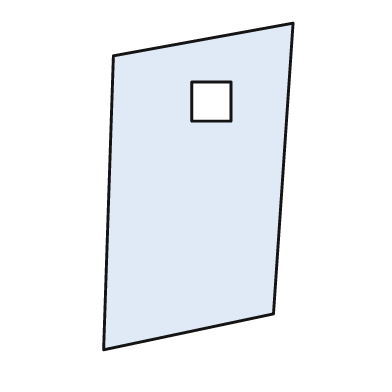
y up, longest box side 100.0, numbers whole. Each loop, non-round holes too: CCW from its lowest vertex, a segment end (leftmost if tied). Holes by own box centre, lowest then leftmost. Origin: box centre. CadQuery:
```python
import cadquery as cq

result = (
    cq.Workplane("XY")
    .moveTo(-29.0, -50.0)
    .lineTo(23.0, -39.0)
    .lineTo(29.0, 50.0)
    .lineTo(-26.0, 40.0)
    .close()
    .moveTo(-2.0, 20.0)
    .lineTo(10.0, 20.0)
    .lineTo(10.0, 32.0)
    .lineTo(-2.0, 32.0)
    .close()
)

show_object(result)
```